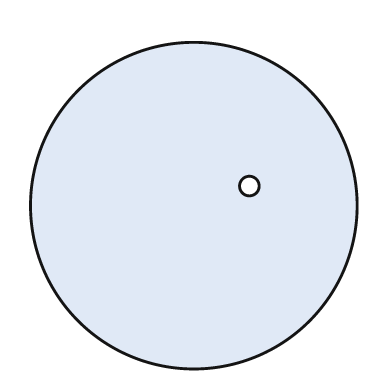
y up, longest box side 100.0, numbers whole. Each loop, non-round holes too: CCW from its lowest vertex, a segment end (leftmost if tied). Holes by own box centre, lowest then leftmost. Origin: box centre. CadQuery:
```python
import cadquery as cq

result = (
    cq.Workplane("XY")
    .moveTo(0.0, 0.0)
    .circle(50.0)
    .moveTo(17.0, 6.0)
    .circle(3.0)
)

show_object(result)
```